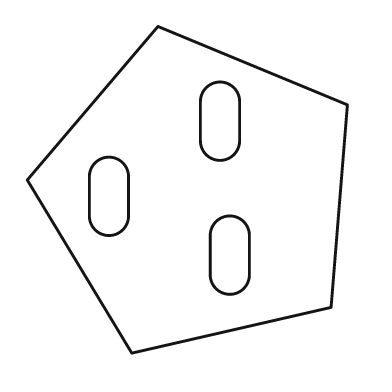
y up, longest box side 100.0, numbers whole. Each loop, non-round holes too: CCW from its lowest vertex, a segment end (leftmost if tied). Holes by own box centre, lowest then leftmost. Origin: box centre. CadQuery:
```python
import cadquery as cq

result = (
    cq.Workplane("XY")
    .moveTo(-17.0, -50.0)
    .lineTo(44.0, -36.0)
    .lineTo(49.0, 26.0)
    .lineTo(-9.0, 50.0)
    .lineTo(-49.0, 3.0)
    .close()
    .moveTo(7.0, -26.0)
    .threePointArc((13.0, -32.0), (19.0, -26.0))
    .lineTo(19.0, -14.0)
    .threePointArc((13.0, -8.0), (7.0, -14.0))
    .close()
    .moveTo(-30.0, -8.0)
    .threePointArc((-24.0, -14.0), (-18.0, -8.0))
    .lineTo(-18.0, 4.0)
    .threePointArc((-24.0, 10.0), (-30.0, 4.0))
    .close()
    .moveTo(4.0, 15.0)
    .threePointArc((10.0, 9.0), (16.0, 15.0))
    .lineTo(16.0, 27.0)
    .threePointArc((10.0, 33.0), (4.0, 27.0))
    .close()
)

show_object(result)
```